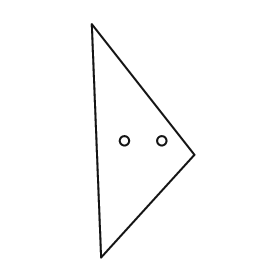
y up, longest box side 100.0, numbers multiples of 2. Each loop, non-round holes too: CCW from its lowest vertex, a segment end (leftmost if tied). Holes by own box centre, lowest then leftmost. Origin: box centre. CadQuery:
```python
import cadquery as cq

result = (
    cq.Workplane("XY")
    .moveTo(-18.0, -50.0)
    .lineTo(22.0, -6.0)
    .lineTo(-22.0, 50.0)
    .close()
    .moveTo(-8.0, 0.0)
    .circle(2.0)
    .moveTo(8.0, 0.0)
    .circle(2.0)
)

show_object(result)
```